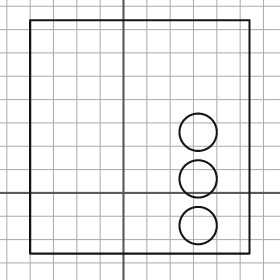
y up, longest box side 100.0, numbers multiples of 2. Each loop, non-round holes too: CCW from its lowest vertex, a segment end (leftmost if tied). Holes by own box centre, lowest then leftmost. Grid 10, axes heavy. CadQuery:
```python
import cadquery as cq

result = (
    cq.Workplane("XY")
    .moveTo(-40.0, -26.0)
    .lineTo(54.0, -26.0)
    .lineTo(54.0, 74.0)
    .lineTo(-40.0, 74.0)
    .close()
    .moveTo(32.0, -14.0)
    .circle(8.0)
    .moveTo(32.0, 6.0)
    .circle(8.0)
    .moveTo(32.0, 26.0)
    .circle(8.0)
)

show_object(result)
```